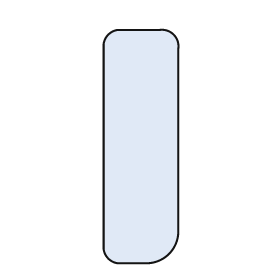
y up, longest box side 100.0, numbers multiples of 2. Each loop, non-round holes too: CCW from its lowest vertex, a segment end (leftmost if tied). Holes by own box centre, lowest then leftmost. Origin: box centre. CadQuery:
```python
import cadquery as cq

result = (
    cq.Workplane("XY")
    .moveTo(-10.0, -50.0)
    .lineTo(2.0, -50.0)
    .threePointArc((12.0, -46.0), (16.0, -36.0))
    .lineTo(16.0, 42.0)
    .threePointArc((14.0, 48.0), (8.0, 50.0))
    .lineTo(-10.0, 50.0)
    .threePointArc((-14.0, 48.0), (-16.0, 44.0))
    .lineTo(-16.0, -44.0)
    .threePointArc((-14.0, -48.0), (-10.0, -50.0))
    .close()
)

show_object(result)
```